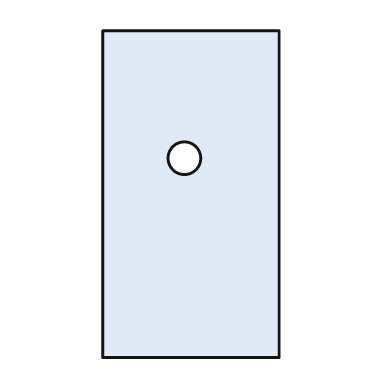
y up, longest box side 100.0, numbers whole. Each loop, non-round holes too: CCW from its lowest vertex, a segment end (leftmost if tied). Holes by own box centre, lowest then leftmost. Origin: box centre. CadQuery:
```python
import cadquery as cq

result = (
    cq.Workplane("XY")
    .moveTo(-27.0, -50.0)
    .lineTo(27.0, -50.0)
    .lineTo(27.0, 50.0)
    .lineTo(-27.0, 50.0)
    .close()
    .moveTo(-2.0, 11.0)
    .circle(5.0)
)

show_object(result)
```